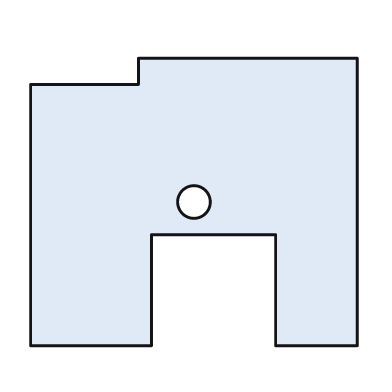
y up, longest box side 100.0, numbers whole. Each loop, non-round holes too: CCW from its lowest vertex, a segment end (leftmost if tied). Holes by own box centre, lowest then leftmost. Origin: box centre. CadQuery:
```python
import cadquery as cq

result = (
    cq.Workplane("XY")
    .moveTo(-50.0, -44.0)
    .lineTo(-13.0, -44.0)
    .lineTo(-13.0, -10.0)
    .lineTo(25.0, -10.0)
    .lineTo(25.0, -44.0)
    .lineTo(50.0, -44.0)
    .lineTo(50.0, 44.0)
    .lineTo(-17.0, 44.0)
    .lineTo(-17.0, 36.0)
    .lineTo(-50.0, 36.0)
    .close()
    .moveTo(0.0, 0.0)
    .circle(5.0)
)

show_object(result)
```